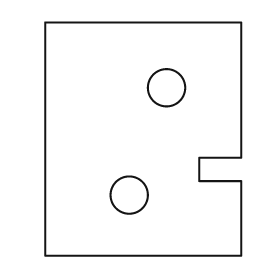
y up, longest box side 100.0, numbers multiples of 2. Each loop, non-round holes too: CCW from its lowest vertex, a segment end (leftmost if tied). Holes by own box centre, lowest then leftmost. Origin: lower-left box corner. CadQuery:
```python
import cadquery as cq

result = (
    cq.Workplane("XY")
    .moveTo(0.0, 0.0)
    .lineTo(84.0, 0.0)
    .lineTo(84.0, 32.0)
    .lineTo(66.0, 32.0)
    .lineTo(66.0, 42.0)
    .lineTo(84.0, 42.0)
    .lineTo(84.0, 100.0)
    .lineTo(0.0, 100.0)
    .close()
    .moveTo(36.0, 26.0)
    .circle(8.0)
    .moveTo(52.0, 72.0)
    .circle(8.0)
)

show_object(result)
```